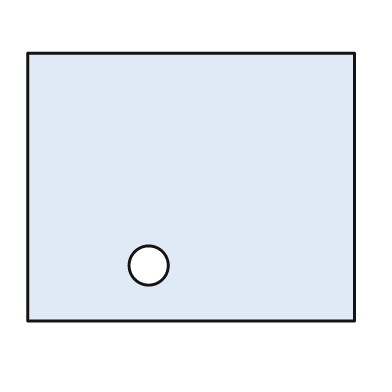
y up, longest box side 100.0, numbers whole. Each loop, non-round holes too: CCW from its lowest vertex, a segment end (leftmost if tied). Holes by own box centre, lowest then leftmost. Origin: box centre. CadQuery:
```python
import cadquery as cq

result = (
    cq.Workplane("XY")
    .moveTo(-50.0, -41.0)
    .lineTo(50.0, -41.0)
    .lineTo(50.0, 41.0)
    .lineTo(-50.0, 41.0)
    .close()
    .moveTo(-13.0, -24.0)
    .circle(6.0)
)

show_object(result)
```